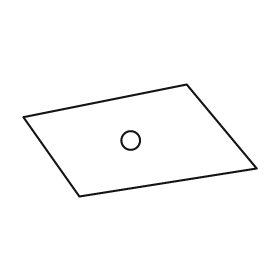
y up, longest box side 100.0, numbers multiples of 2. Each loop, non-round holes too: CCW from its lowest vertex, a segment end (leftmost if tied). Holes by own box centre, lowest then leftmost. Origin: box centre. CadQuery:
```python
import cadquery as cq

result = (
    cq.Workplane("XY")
    .moveTo(-26.0, -24.0)
    .lineTo(50.0, -12.0)
    .lineTo(20.0, 24.0)
    .lineTo(-50.0, 10.0)
    .close()
    .moveTo(-4.0, 0.0)
    .circle(4.0)
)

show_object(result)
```